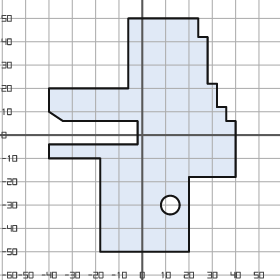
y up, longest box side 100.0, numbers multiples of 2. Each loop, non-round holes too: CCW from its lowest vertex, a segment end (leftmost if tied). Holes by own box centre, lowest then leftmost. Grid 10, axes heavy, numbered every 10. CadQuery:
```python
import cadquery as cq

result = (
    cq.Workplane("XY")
    .moveTo(-18.0, -50.0)
    .lineTo(20.0, -50.0)
    .lineTo(20.0, -18.0)
    .lineTo(40.0, -18.0)
    .lineTo(40.0, 6.0)
    .lineTo(36.0, 6.0)
    .lineTo(36.0, 12.0)
    .lineTo(32.0, 12.0)
    .lineTo(32.0, 22.0)
    .lineTo(28.0, 22.0)
    .lineTo(28.0, 42.0)
    .lineTo(24.0, 42.0)
    .lineTo(24.0, 50.0)
    .lineTo(-6.0, 50.0)
    .lineTo(-6.0, 20.0)
    .lineTo(-40.0, 20.0)
    .lineTo(-40.0, 10.0)
    .lineTo(-34.0, 6.0)
    .lineTo(-2.0, 6.0)
    .lineTo(-2.0, -4.0)
    .lineTo(-40.0, -4.0)
    .lineTo(-40.0, -10.0)
    .lineTo(-18.0, -10.0)
    .close()
    .moveTo(12.0, -30.0)
    .circle(4.0)
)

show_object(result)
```